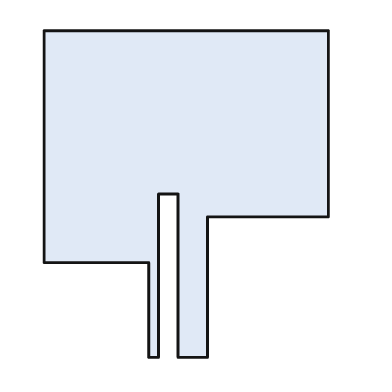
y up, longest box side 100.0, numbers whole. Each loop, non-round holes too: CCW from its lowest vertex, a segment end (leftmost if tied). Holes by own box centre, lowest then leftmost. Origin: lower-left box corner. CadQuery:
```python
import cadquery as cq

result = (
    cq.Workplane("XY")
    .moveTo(32.0, 0.0)
    .lineTo(35.0, 0.0)
    .lineTo(35.0, 50.0)
    .lineTo(41.0, 50.0)
    .lineTo(41.0, 0.0)
    .lineTo(50.0, 0.0)
    .lineTo(50.0, 43.0)
    .lineTo(87.0, 43.0)
    .lineTo(87.0, 100.0)
    .lineTo(0.0, 100.0)
    .lineTo(0.0, 29.0)
    .lineTo(32.0, 29.0)
    .close()
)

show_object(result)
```